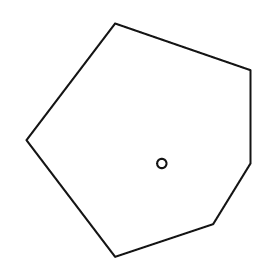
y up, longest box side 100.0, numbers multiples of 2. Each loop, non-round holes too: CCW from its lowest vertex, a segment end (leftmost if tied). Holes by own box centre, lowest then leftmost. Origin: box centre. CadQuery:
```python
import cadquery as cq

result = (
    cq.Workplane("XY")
    .moveTo(-10.0, -50.0)
    .lineTo(32.0, -36.0)
    .lineTo(48.0, -10.0)
    .lineTo(48.0, 30.0)
    .lineTo(-10.0, 50.0)
    .lineTo(-48.0, 0.0)
    .close()
    .moveTo(10.0, -10.0)
    .circle(2.0)
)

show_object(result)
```